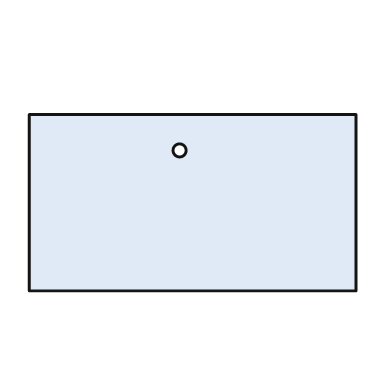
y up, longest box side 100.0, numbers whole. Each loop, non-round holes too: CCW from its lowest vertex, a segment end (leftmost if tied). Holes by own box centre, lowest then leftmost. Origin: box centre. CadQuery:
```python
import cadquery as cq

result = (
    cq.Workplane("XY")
    .moveTo(-50.0, -27.0)
    .lineTo(50.0, -27.0)
    .lineTo(50.0, 27.0)
    .lineTo(-50.0, 27.0)
    .close()
    .moveTo(-4.0, 16.0)
    .circle(2.0)
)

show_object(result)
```